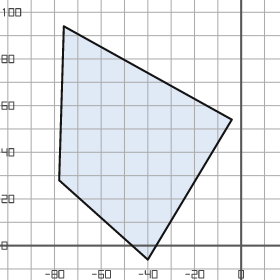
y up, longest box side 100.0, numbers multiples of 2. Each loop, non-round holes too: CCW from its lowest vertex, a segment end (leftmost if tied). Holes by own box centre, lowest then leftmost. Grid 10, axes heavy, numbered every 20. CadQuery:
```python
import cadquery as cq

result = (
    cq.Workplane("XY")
    .moveTo(-40.0, -6.0)
    .lineTo(-4.0, 54.0)
    .lineTo(-76.0, 94.0)
    .lineTo(-78.0, 28.0)
    .close()
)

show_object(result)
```